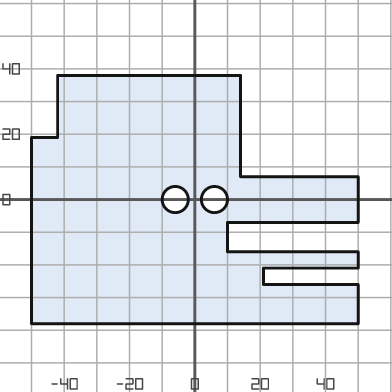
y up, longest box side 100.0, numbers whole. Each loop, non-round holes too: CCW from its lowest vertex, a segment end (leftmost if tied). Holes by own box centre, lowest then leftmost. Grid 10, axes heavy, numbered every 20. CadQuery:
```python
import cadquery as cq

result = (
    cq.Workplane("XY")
    .moveTo(-50.0, -38.0)
    .lineTo(50.0, -38.0)
    .lineTo(50.0, -26.0)
    .lineTo(21.0, -26.0)
    .lineTo(21.0, -21.0)
    .lineTo(50.0, -21.0)
    .lineTo(50.0, -16.0)
    .lineTo(10.0, -16.0)
    .lineTo(10.0, -7.0)
    .lineTo(50.0, -7.0)
    .lineTo(50.0, 7.0)
    .lineTo(14.0, 7.0)
    .lineTo(14.0, 38.0)
    .lineTo(-42.0, 38.0)
    .lineTo(-42.0, 19.0)
    .lineTo(-50.0, 19.0)
    .close()
    .moveTo(-6.0, 0.0)
    .circle(4.0)
    .moveTo(6.0, 0.0)
    .circle(4.0)
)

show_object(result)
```